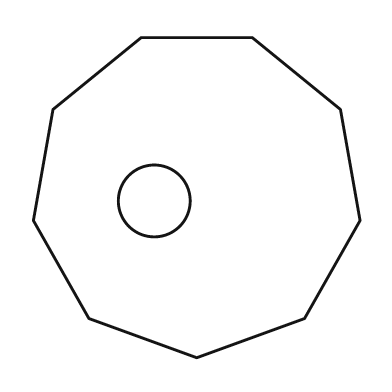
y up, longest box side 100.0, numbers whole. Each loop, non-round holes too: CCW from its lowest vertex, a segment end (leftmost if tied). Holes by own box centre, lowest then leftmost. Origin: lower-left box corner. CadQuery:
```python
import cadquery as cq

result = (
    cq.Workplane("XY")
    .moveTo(50.0, 0.0)
    .lineTo(83.0, 12.0)
    .lineTo(100.0, 42.0)
    .lineTo(94.0, 76.0)
    .lineTo(67.0, 98.0)
    .lineTo(33.0, 98.0)
    .lineTo(6.0, 76.0)
    .lineTo(0.0, 42.0)
    .lineTo(17.0, 12.0)
    .close()
    .moveTo(37.0, 48.0)
    .circle(11.0)
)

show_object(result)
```